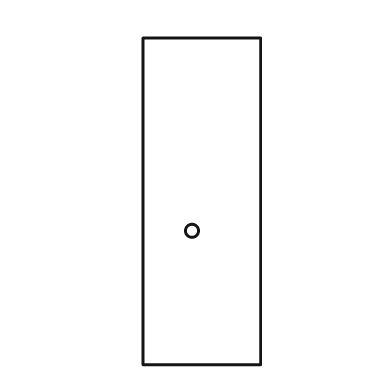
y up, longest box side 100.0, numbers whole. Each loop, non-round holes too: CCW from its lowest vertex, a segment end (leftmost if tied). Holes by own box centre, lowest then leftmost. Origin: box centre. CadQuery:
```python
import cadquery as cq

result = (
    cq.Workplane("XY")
    .moveTo(-18.0, -50.0)
    .lineTo(18.0, -50.0)
    .lineTo(18.0, 50.0)
    .lineTo(-18.0, 50.0)
    .close()
    .moveTo(-3.0, -9.0)
    .circle(2.0)
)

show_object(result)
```